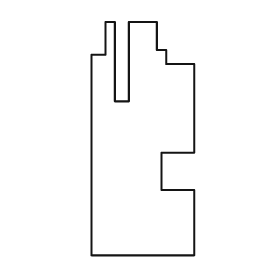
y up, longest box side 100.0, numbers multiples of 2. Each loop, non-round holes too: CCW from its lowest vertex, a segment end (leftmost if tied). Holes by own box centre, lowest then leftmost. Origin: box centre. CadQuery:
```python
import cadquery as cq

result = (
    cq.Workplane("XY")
    .moveTo(-22.0, -50.0)
    .lineTo(22.0, -50.0)
    .lineTo(22.0, -22.0)
    .lineTo(8.0, -22.0)
    .lineTo(8.0, -6.0)
    .lineTo(22.0, -6.0)
    .lineTo(22.0, 32.0)
    .lineTo(10.0, 32.0)
    .lineTo(10.0, 38.0)
    .lineTo(6.0, 38.0)
    .lineTo(6.0, 50.0)
    .lineTo(-6.0, 50.0)
    .lineTo(-6.0, 16.0)
    .lineTo(-12.0, 16.0)
    .lineTo(-12.0, 50.0)
    .lineTo(-16.0, 50.0)
    .lineTo(-16.0, 36.0)
    .lineTo(-22.0, 36.0)
    .close()
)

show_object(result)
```